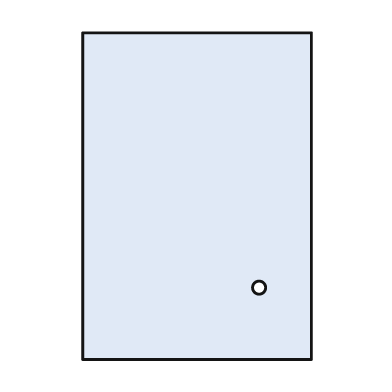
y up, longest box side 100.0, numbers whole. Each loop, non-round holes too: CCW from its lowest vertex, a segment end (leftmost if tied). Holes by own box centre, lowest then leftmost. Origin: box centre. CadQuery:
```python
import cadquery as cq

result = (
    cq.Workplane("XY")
    .moveTo(-35.0, -50.0)
    .lineTo(35.0, -50.0)
    .lineTo(35.0, 50.0)
    .lineTo(-35.0, 50.0)
    .close()
    .moveTo(19.0, -28.0)
    .circle(2.0)
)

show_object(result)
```